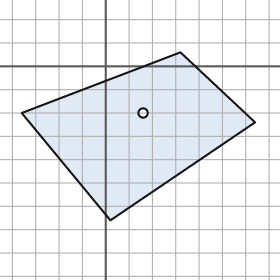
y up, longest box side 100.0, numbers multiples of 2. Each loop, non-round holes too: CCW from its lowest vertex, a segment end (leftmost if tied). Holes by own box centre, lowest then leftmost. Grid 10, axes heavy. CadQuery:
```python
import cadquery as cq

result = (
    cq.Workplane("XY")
    .moveTo(2.0, -66.0)
    .lineTo(64.0, -24.0)
    .lineTo(32.0, 6.0)
    .lineTo(-36.0, -20.0)
    .close()
    .moveTo(16.0, -20.0)
    .circle(2.0)
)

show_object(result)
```